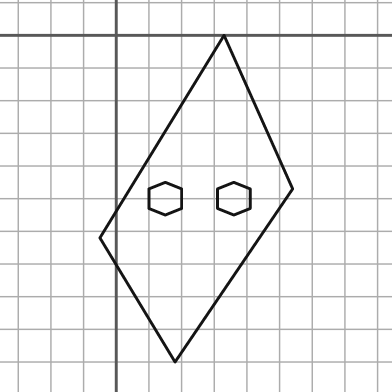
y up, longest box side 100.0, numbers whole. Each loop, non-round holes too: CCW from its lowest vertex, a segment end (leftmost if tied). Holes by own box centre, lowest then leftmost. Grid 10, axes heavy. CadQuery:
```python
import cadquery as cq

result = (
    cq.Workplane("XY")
    .moveTo(18.0, -100.0)
    .lineTo(54.0, -47.0)
    .lineTo(33.0, 0.0)
    .lineTo(-5.0, -62.0)
    .close()
    .moveTo(15.0, -55.0)
    .lineTo(20.0, -53.0)
    .lineTo(20.0, -47.0)
    .lineTo(15.0, -45.0)
    .lineTo(10.0, -47.0)
    .lineTo(10.0, -53.0)
    .close()
    .moveTo(36.0, -55.0)
    .lineTo(41.0, -53.0)
    .lineTo(41.0, -47.0)
    .lineTo(36.0, -45.0)
    .lineTo(31.0, -47.0)
    .lineTo(31.0, -53.0)
    .close()
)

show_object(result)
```